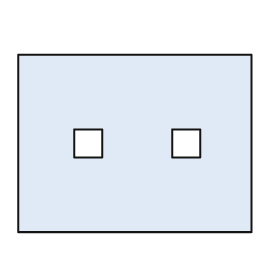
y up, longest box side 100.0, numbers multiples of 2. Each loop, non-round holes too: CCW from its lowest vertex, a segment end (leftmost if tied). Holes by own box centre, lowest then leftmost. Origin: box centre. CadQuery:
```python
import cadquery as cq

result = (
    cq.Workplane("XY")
    .moveTo(-50.0, -38.0)
    .lineTo(50.0, -38.0)
    .lineTo(50.0, 38.0)
    .lineTo(-50.0, 38.0)
    .close()
    .moveTo(-26.0, -6.0)
    .lineTo(-14.0, -6.0)
    .lineTo(-14.0, 6.0)
    .lineTo(-26.0, 6.0)
    .close()
    .moveTo(16.0, -6.0)
    .lineTo(28.0, -6.0)
    .lineTo(28.0, 6.0)
    .lineTo(16.0, 6.0)
    .close()
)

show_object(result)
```